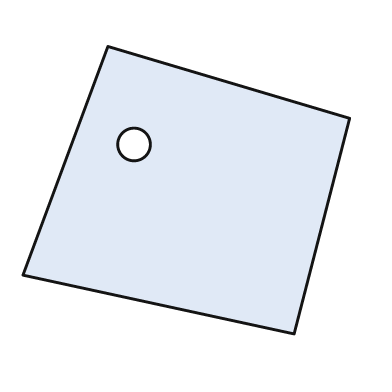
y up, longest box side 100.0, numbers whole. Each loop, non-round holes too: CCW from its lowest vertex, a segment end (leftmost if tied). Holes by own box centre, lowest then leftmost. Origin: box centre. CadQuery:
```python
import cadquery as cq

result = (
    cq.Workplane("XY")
    .moveTo(33.0, -44.0)
    .lineTo(50.0, 22.0)
    .lineTo(-24.0, 44.0)
    .lineTo(-50.0, -26.0)
    .close()
    .moveTo(-16.0, 14.0)
    .circle(5.0)
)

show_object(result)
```